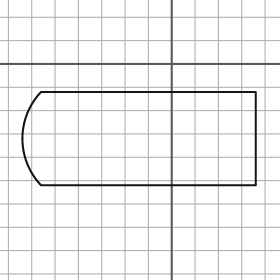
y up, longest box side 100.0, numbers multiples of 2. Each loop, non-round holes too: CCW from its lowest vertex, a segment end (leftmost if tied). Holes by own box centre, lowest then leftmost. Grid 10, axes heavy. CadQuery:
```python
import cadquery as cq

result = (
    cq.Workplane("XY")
    .moveTo(-56.0, -52.0)
    .lineTo(36.0, -52.0)
    .lineTo(36.0, -12.0)
    .lineTo(-56.0, -12.0)
    .threePointArc((-64.0, -32.0), (-56.0, -52.0))
    .close()
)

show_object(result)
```